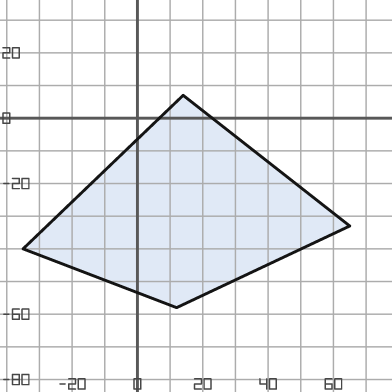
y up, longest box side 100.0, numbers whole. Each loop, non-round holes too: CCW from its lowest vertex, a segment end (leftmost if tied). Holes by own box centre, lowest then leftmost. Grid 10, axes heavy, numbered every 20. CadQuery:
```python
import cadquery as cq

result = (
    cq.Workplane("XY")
    .moveTo(12.0, -58.0)
    .lineTo(65.0, -33.0)
    .lineTo(14.0, 7.0)
    .lineTo(-35.0, -40.0)
    .close()
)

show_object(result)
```